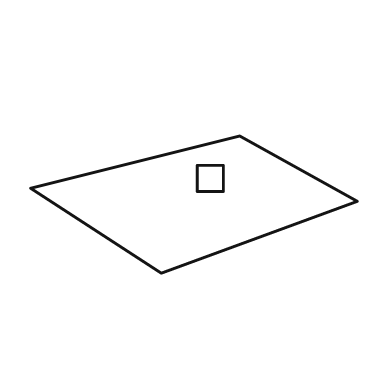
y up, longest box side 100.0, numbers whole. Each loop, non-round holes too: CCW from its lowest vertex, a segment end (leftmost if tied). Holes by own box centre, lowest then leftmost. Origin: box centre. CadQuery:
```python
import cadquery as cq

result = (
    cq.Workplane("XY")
    .moveTo(-10.0, -21.0)
    .lineTo(50.0, 1.0)
    .lineTo(14.0, 21.0)
    .lineTo(-50.0, 5.0)
    .close()
    .moveTo(1.0, 4.0)
    .lineTo(9.0, 4.0)
    .lineTo(9.0, 12.0)
    .lineTo(1.0, 12.0)
    .close()
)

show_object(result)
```